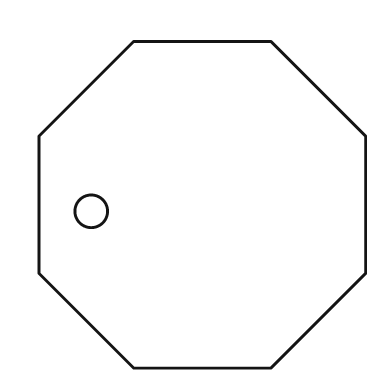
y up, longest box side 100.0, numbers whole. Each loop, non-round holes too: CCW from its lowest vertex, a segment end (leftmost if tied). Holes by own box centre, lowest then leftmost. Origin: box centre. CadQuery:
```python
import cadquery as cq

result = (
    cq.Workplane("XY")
    .moveTo(-21.0, -50.0)
    .lineTo(21.0, -50.0)
    .lineTo(50.0, -21.0)
    .lineTo(50.0, 21.0)
    .lineTo(21.0, 50.0)
    .lineTo(-21.0, 50.0)
    .lineTo(-50.0, 21.0)
    .lineTo(-50.0, -21.0)
    .close()
    .moveTo(-34.0, -2.0)
    .circle(5.0)
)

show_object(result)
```